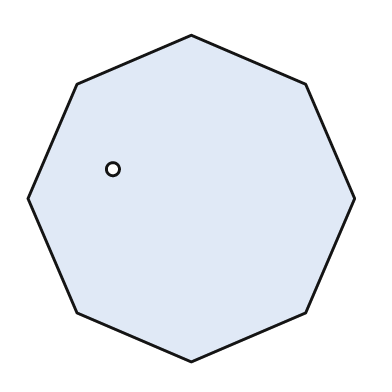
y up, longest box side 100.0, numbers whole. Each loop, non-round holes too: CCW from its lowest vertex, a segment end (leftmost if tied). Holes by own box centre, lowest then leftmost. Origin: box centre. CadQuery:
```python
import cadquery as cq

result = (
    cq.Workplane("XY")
    .moveTo(0.0, -50.0)
    .lineTo(35.0, -35.0)
    .lineTo(50.0, 0.0)
    .lineTo(35.0, 35.0)
    .lineTo(0.0, 50.0)
    .lineTo(-35.0, 35.0)
    .lineTo(-50.0, 0.0)
    .lineTo(-35.0, -35.0)
    .close()
    .moveTo(-24.0, 9.0)
    .circle(2.0)
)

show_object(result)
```